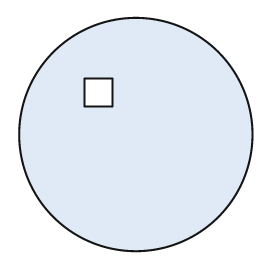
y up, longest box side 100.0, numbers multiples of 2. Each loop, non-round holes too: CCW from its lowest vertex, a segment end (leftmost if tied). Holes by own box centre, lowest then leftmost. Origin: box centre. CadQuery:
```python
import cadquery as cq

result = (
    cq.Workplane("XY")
    .moveTo(0.0, 0.0)
    .circle(50.0)
    .moveTo(-22.0, 12.0)
    .lineTo(-10.0, 12.0)
    .lineTo(-10.0, 24.0)
    .lineTo(-22.0, 24.0)
    .close()
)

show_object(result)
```